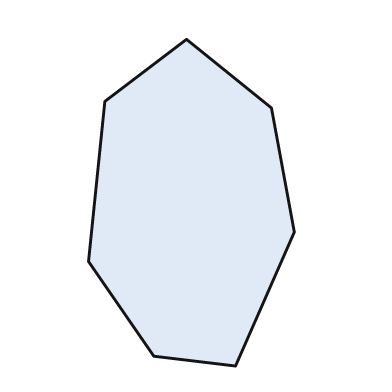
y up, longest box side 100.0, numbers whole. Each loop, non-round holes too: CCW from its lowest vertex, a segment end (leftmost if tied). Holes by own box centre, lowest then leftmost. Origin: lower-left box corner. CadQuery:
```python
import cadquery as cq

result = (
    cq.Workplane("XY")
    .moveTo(45.0, 0.0)
    .lineTo(63.0, 41.0)
    .lineTo(56.0, 79.0)
    .lineTo(30.0, 100.0)
    .lineTo(5.0, 81.0)
    .lineTo(0.0, 32.0)
    .lineTo(20.0, 3.0)
    .close()
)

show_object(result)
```